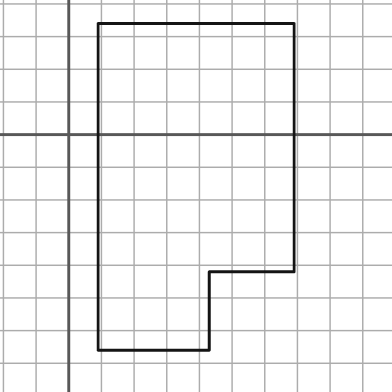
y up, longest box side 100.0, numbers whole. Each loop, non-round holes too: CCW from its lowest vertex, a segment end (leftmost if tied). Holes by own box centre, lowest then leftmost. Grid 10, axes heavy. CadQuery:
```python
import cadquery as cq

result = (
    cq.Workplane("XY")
    .moveTo(9.0, -66.0)
    .lineTo(43.0, -66.0)
    .lineTo(43.0, -42.0)
    .lineTo(69.0, -42.0)
    .lineTo(69.0, 34.0)
    .lineTo(9.0, 34.0)
    .close()
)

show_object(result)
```